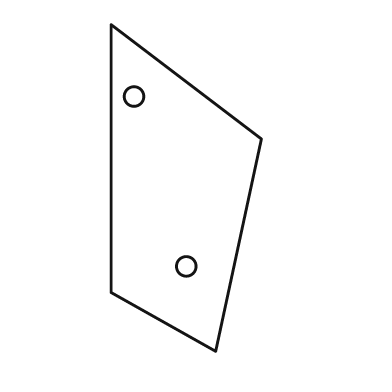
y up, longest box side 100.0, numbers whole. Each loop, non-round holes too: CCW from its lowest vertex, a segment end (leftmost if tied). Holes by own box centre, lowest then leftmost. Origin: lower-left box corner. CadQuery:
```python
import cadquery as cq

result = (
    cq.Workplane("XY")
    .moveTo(32.0, 0.0)
    .lineTo(46.0, 65.0)
    .lineTo(0.0, 100.0)
    .lineTo(0.0, 18.0)
    .close()
    .moveTo(23.0, 26.0)
    .circle(3.0)
    .moveTo(7.0, 78.0)
    .circle(3.0)
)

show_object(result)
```